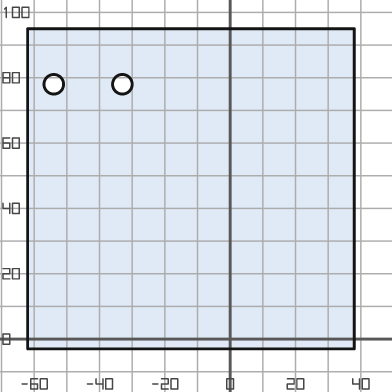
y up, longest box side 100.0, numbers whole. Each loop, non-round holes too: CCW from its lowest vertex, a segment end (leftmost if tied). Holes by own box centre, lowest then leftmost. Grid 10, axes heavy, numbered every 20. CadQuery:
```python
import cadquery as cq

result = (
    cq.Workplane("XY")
    .moveTo(-62.0, -3.0)
    .lineTo(38.0, -3.0)
    .lineTo(38.0, 95.0)
    .lineTo(-62.0, 95.0)
    .close()
    .moveTo(-54.0, 78.0)
    .circle(3.0)
    .moveTo(-33.0, 78.0)
    .circle(3.0)
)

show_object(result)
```